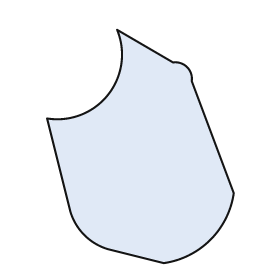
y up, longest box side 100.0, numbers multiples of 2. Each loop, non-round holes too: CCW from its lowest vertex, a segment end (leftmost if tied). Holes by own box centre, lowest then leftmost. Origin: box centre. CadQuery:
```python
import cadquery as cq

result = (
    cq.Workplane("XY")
    .moveTo(10.0, -50.0)
    .threePointArc((30.0, -40.0), (40.0, -20.0))
    .lineTo(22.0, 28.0)
    .threePointArc((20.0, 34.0), (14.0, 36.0))
    .lineTo(-10.0, 50.0)
    .threePointArc((-14.0, 22.0), (-40.0, 12.0))
    .lineTo(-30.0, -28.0)
    .threePointArc((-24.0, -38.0), (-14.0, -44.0))
    .close()
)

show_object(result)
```